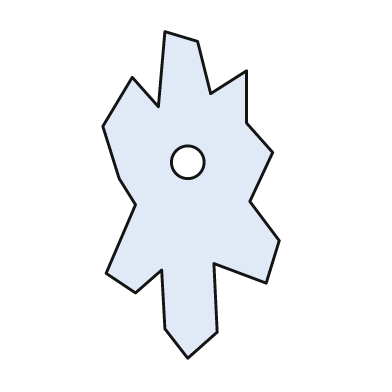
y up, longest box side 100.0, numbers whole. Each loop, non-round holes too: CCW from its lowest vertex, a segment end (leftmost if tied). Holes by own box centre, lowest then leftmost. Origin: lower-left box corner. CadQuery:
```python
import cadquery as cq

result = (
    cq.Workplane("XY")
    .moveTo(26.0, 0.0)
    .lineTo(35.0, 8.0)
    .lineTo(34.0, 29.0)
    .lineTo(50.0, 23.0)
    .lineTo(54.0, 36.0)
    .lineTo(45.0, 48.0)
    .lineTo(52.0, 63.0)
    .lineTo(44.0, 72.0)
    .lineTo(44.0, 88.0)
    .lineTo(33.0, 81.0)
    .lineTo(29.0, 97.0)
    .lineTo(19.0, 100.0)
    .lineTo(17.0, 77.0)
    .lineTo(9.0, 86.0)
    .lineTo(0.0, 71.0)
    .lineTo(5.0, 55.0)
    .lineTo(10.0, 47.0)
    .lineTo(1.0, 26.0)
    .lineTo(10.0, 20.0)
    .lineTo(18.0, 27.0)
    .lineTo(19.0, 9.0)
    .close()
    .moveTo(26.0, 60.0)
    .circle(5.0)
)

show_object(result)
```